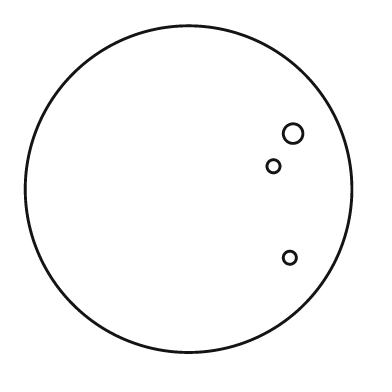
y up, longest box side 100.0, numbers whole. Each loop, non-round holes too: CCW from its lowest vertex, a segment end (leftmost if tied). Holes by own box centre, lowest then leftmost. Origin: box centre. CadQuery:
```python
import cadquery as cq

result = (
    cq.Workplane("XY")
    .moveTo(0.0, 0.0)
    .circle(50.0)
    .moveTo(31.0, -21.0)
    .circle(2.0)
    .moveTo(26.0, 7.0)
    .circle(2.0)
    .moveTo(32.0, 17.0)
    .circle(3.0)
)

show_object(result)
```